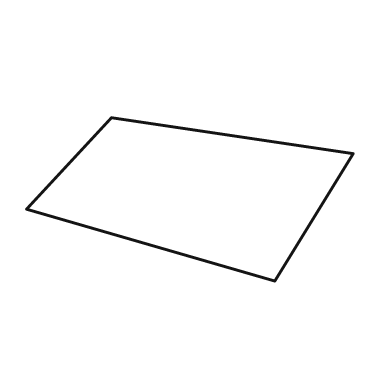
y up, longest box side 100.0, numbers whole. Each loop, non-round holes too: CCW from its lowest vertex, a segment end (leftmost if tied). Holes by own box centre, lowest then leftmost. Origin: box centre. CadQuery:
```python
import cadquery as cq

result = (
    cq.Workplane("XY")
    .moveTo(26.0, -25.0)
    .lineTo(50.0, 14.0)
    .lineTo(-24.0, 25.0)
    .lineTo(-50.0, -3.0)
    .close()
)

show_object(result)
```